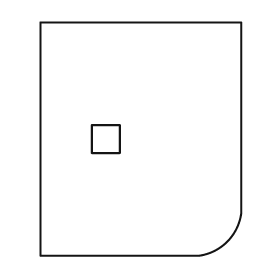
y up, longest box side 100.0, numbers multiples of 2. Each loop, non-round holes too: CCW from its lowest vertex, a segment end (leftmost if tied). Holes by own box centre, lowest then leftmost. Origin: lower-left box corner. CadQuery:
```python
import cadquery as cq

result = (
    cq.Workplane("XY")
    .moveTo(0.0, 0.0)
    .lineTo(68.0, 0.0)
    .threePointArc((80.0, 6.0), (86.0, 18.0))
    .lineTo(86.0, 100.0)
    .lineTo(0.0, 100.0)
    .close()
    .moveTo(22.0, 44.0)
    .lineTo(34.0, 44.0)
    .lineTo(34.0, 56.0)
    .lineTo(22.0, 56.0)
    .close()
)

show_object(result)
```